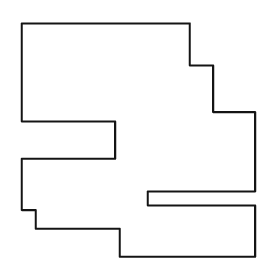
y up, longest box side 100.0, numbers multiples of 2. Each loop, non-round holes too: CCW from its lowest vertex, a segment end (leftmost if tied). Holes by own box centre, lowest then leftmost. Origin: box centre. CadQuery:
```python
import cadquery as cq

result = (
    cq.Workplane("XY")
    .moveTo(-8.0, -50.0)
    .lineTo(50.0, -50.0)
    .lineTo(50.0, -28.0)
    .lineTo(4.0, -28.0)
    .lineTo(4.0, -22.0)
    .lineTo(50.0, -22.0)
    .lineTo(50.0, 12.0)
    .lineTo(32.0, 12.0)
    .lineTo(32.0, 32.0)
    .lineTo(22.0, 32.0)
    .lineTo(22.0, 50.0)
    .lineTo(-50.0, 50.0)
    .lineTo(-50.0, 8.0)
    .lineTo(-10.0, 8.0)
    .lineTo(-10.0, -8.0)
    .lineTo(-50.0, -8.0)
    .lineTo(-50.0, -30.0)
    .lineTo(-44.0, -30.0)
    .lineTo(-44.0, -38.0)
    .lineTo(-8.0, -38.0)
    .close()
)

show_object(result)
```